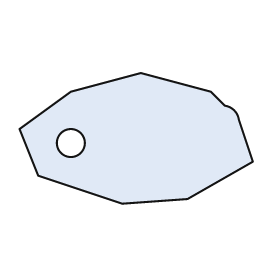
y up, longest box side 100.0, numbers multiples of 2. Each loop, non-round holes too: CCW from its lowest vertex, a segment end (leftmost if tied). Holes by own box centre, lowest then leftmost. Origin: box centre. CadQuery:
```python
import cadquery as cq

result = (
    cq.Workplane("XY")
    .moveTo(-6.0, -28.0)
    .lineTo(22.0, -26.0)
    .lineTo(50.0, -10.0)
    .lineTo(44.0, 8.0)
    .threePointArc((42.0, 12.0), (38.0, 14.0))
    .lineTo(32.0, 20.0)
    .lineTo(2.0, 28.0)
    .lineTo(-28.0, 20.0)
    .lineTo(-50.0, 4.0)
    .lineTo(-42.0, -16.0)
    .close()
    .moveTo(-28.0, -2.0)
    .circle(6.0)
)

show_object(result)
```